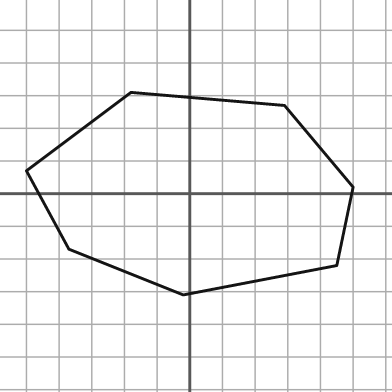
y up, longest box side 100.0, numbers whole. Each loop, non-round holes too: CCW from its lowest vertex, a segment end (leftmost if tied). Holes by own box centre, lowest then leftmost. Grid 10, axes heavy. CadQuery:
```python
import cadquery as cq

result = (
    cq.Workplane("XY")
    .moveTo(-2.0, -31.0)
    .lineTo(45.0, -22.0)
    .lineTo(50.0, 2.0)
    .lineTo(29.0, 27.0)
    .lineTo(-18.0, 31.0)
    .lineTo(-50.0, 7.0)
    .lineTo(-37.0, -17.0)
    .close()
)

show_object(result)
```